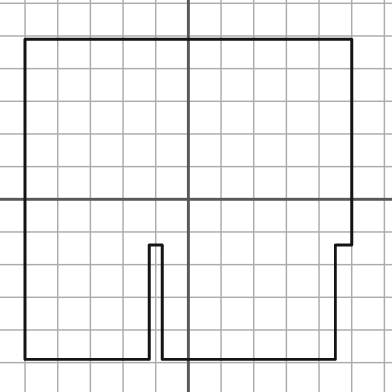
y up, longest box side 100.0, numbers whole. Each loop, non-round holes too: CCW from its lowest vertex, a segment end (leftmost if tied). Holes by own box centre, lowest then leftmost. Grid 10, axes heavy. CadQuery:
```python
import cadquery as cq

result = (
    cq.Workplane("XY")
    .moveTo(-50.0, -49.0)
    .lineTo(-12.0, -49.0)
    .lineTo(-12.0, -14.0)
    .lineTo(-8.0, -14.0)
    .lineTo(-8.0, -49.0)
    .lineTo(45.0, -49.0)
    .lineTo(45.0, -14.0)
    .lineTo(50.0, -14.0)
    .lineTo(50.0, 49.0)
    .lineTo(-50.0, 49.0)
    .close()
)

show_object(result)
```